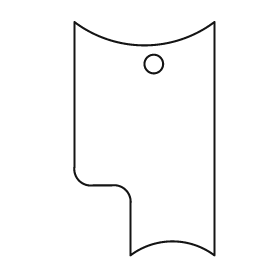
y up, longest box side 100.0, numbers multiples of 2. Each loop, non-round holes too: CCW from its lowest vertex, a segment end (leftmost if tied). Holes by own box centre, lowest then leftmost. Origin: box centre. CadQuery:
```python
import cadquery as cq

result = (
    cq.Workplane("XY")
    .moveTo(-6.0, -50.0)
    .threePointArc((12.0, -44.0), (30.0, -50.0))
    .lineTo(30.0, 50.0)
    .threePointArc((0.0, 40.0), (-30.0, 50.0))
    .lineTo(-30.0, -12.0)
    .threePointArc((-28.0, -18.0), (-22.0, -20.0))
    .lineTo(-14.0, -20.0)
    .threePointArc((-8.0, -22.0), (-6.0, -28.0))
    .close()
    .moveTo(4.0, 32.0)
    .circle(4.0)
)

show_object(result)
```